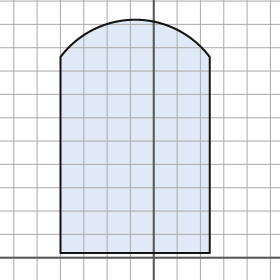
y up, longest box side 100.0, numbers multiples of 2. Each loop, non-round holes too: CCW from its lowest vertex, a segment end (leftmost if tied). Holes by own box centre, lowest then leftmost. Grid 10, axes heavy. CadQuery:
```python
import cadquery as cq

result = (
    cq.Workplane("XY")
    .moveTo(-40.0, 2.0)
    .lineTo(24.0, 2.0)
    .lineTo(24.0, 86.0)
    .threePointArc((-8.0, 102.0), (-40.0, 86.0))
    .close()
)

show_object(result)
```